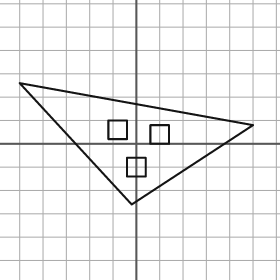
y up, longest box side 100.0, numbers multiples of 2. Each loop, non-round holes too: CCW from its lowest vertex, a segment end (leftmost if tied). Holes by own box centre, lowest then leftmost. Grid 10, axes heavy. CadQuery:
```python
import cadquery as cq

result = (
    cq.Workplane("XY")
    .moveTo(-2.0, -26.0)
    .lineTo(50.0, 8.0)
    .lineTo(-50.0, 26.0)
    .close()
    .moveTo(-4.0, -14.0)
    .lineTo(4.0, -14.0)
    .lineTo(4.0, -6.0)
    .lineTo(-4.0, -6.0)
    .close()
    .moveTo(6.0, 0.0)
    .lineTo(14.0, 0.0)
    .lineTo(14.0, 8.0)
    .lineTo(6.0, 8.0)
    .close()
    .moveTo(-12.0, 2.0)
    .lineTo(-4.0, 2.0)
    .lineTo(-4.0, 10.0)
    .lineTo(-12.0, 10.0)
    .close()
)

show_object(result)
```